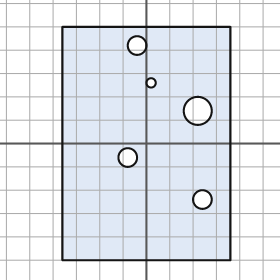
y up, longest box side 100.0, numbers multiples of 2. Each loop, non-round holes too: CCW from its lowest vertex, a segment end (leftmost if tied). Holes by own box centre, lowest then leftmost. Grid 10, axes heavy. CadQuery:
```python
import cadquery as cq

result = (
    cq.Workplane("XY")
    .moveTo(-36.0, -50.0)
    .lineTo(36.0, -50.0)
    .lineTo(36.0, 50.0)
    .lineTo(-36.0, 50.0)
    .close()
    .moveTo(24.0, -24.0)
    .circle(4.0)
    .moveTo(-8.0, -6.0)
    .circle(4.0)
    .moveTo(22.0, 14.0)
    .circle(6.0)
    .moveTo(2.0, 26.0)
    .circle(2.0)
    .moveTo(-4.0, 42.0)
    .circle(4.0)
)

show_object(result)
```